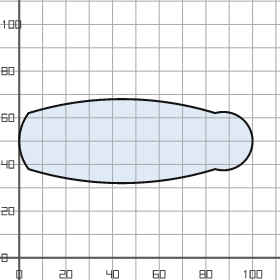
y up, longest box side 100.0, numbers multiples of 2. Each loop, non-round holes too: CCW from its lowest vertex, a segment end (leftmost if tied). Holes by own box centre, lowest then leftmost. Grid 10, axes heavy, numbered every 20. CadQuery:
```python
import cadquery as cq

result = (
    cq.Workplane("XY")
    .moveTo(4.0, 38.0)
    .threePointArc((44.0, 32.0), (84.0, 38.0))
    .threePointArc((100.0, 50.0), (84.0, 62.0))
    .threePointArc((44.0, 68.0), (4.0, 62.0))
    .threePointArc((0.0, 50.0), (4.0, 38.0))
    .close()
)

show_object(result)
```